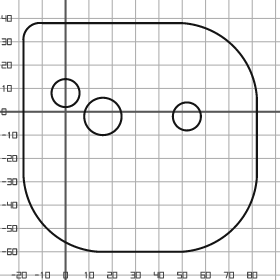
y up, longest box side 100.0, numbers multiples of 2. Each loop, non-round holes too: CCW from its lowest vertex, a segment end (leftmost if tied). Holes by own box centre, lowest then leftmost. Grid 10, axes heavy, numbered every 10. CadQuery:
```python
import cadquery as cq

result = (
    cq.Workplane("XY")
    .moveTo(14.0, -60.0)
    .lineTo(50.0, -60.0)
    .threePointArc((72.0, -50.0), (82.0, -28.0))
    .lineTo(82.0, 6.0)
    .threePointArc((72.0, 28.0), (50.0, 38.0))
    .lineTo(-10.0, 38.0)
    .threePointArc((-16.0, 36.0), (-18.0, 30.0))
    .lineTo(-18.0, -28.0)
    .threePointArc((-8.0, -50.0), (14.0, -60.0))
    .close()
    .moveTo(16.0, -2.0)
    .circle(8.0)
    .moveTo(52.0, -2.0)
    .circle(6.0)
    .moveTo(0.0, 8.0)
    .circle(6.0)
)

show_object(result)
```